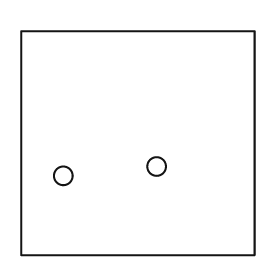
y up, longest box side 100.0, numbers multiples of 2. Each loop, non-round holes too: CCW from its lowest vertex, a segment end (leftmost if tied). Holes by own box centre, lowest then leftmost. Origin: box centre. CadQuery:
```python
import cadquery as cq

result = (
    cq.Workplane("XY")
    .moveTo(-50.0, -48.0)
    .lineTo(50.0, -48.0)
    .lineTo(50.0, 48.0)
    .lineTo(-50.0, 48.0)
    .close()
    .moveTo(-32.0, -14.0)
    .circle(4.0)
    .moveTo(8.0, -10.0)
    .circle(4.0)
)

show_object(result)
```